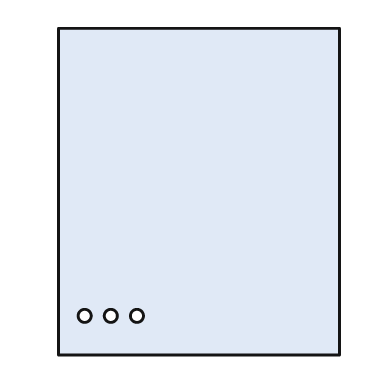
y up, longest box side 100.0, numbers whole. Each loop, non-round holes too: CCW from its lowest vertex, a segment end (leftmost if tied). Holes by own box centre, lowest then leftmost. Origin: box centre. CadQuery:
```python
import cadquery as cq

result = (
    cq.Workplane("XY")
    .moveTo(-43.0, -50.0)
    .lineTo(43.0, -50.0)
    .lineTo(43.0, 50.0)
    .lineTo(-43.0, 50.0)
    .close()
    .moveTo(-35.0, -38.0)
    .circle(2.0)
    .moveTo(-27.0, -38.0)
    .circle(2.0)
    .moveTo(-19.0, -38.0)
    .circle(2.0)
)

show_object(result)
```